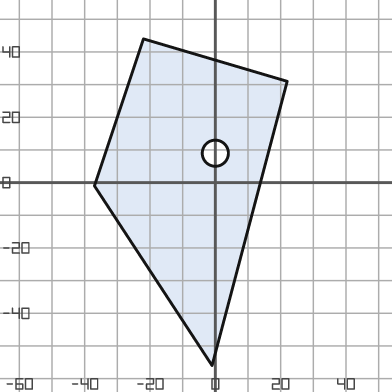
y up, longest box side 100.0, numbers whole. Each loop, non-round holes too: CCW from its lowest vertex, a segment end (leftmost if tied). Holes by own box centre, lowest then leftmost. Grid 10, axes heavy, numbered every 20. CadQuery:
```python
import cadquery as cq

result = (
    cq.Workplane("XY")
    .moveTo(-1.0, -56.0)
    .lineTo(22.0, 31.0)
    .lineTo(-22.0, 44.0)
    .lineTo(-37.0, -1.0)
    .close()
    .moveTo(0.0, 9.0)
    .circle(4.0)
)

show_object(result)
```